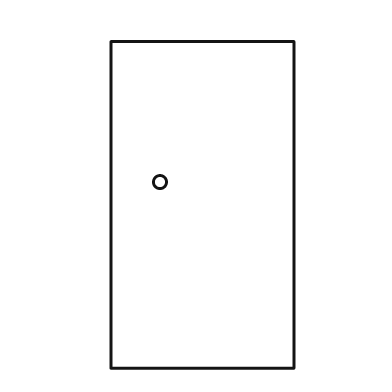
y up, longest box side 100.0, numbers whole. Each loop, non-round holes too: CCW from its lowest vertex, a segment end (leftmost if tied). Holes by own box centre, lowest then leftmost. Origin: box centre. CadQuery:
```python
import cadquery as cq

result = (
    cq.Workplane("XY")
    .moveTo(-28.0, -50.0)
    .lineTo(28.0, -50.0)
    .lineTo(28.0, 50.0)
    .lineTo(-28.0, 50.0)
    .close()
    .moveTo(-13.0, 7.0)
    .circle(2.0)
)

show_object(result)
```